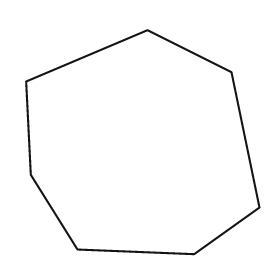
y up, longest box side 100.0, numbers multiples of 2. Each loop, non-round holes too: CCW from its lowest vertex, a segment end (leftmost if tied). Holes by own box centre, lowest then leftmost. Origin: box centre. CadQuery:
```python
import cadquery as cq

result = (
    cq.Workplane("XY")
    .moveTo(22.0, -48.0)
    .lineTo(50.0, -28.0)
    .lineTo(38.0, 30.0)
    .lineTo(2.0, 48.0)
    .lineTo(-50.0, 26.0)
    .lineTo(-48.0, -14.0)
    .lineTo(-28.0, -46.0)
    .close()
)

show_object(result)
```